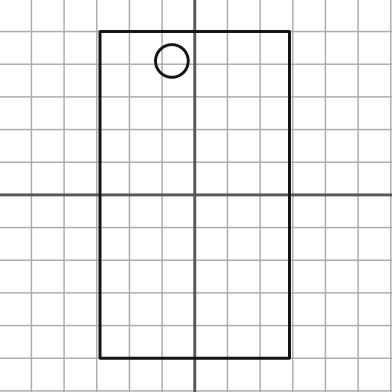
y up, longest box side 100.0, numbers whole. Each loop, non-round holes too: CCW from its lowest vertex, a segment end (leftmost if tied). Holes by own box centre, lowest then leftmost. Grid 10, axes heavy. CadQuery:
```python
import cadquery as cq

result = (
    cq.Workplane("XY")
    .moveTo(-29.0, -50.0)
    .lineTo(29.0, -50.0)
    .lineTo(29.0, 50.0)
    .lineTo(-29.0, 50.0)
    .close()
    .moveTo(-7.0, 41.0)
    .circle(5.0)
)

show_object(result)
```